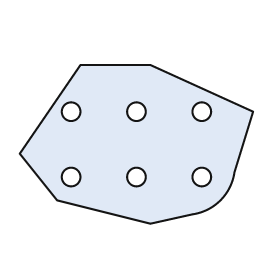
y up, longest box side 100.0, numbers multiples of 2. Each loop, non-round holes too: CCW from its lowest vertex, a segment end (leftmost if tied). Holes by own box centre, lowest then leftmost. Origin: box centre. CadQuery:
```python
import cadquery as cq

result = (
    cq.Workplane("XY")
    .moveTo(6.0, -34.0)
    .lineTo(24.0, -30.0)
    .threePointArc((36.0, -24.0), (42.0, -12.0))
    .lineTo(50.0, 14.0)
    .lineTo(6.0, 34.0)
    .lineTo(-24.0, 34.0)
    .lineTo(-50.0, -4.0)
    .lineTo(-34.0, -24.0)
    .close()
    .moveTo(-28.0, -14.0)
    .circle(4.0)
    .moveTo(0.0, -14.0)
    .circle(4.0)
    .moveTo(28.0, -14.0)
    .circle(4.0)
    .moveTo(-28.0, 14.0)
    .circle(4.0)
    .moveTo(0.0, 14.0)
    .circle(4.0)
    .moveTo(28.0, 14.0)
    .circle(4.0)
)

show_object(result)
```